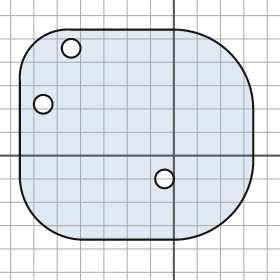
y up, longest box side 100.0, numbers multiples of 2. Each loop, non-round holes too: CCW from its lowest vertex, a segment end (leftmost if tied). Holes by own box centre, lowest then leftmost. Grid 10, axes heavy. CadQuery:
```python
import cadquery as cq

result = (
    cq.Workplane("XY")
    .moveTo(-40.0, -36.0)
    .lineTo(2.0, -36.0)
    .threePointArc((24.0, -26.0), (34.0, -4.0))
    .lineTo(34.0, 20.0)
    .threePointArc((24.0, 44.0), (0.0, 54.0))
    .lineTo(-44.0, 54.0)
    .threePointArc((-60.0, 48.0), (-66.0, 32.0))
    .lineTo(-66.0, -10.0)
    .threePointArc((-58.0, -28.0), (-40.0, -36.0))
    .close()
    .moveTo(-4.0, -10.0)
    .circle(4.0)
    .moveTo(-56.0, 22.0)
    .circle(4.0)
    .moveTo(-44.0, 46.0)
    .circle(4.0)
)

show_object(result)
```